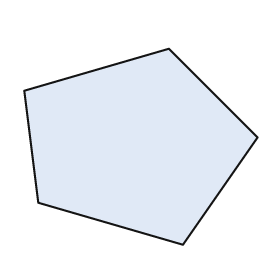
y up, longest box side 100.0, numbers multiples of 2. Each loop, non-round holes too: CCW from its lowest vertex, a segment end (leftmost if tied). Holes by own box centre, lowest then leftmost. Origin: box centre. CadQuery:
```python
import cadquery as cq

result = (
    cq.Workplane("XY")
    .moveTo(18.0, -42.0)
    .lineTo(50.0, 4.0)
    .lineTo(12.0, 42.0)
    .lineTo(-50.0, 24.0)
    .lineTo(-44.0, -24.0)
    .close()
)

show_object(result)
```